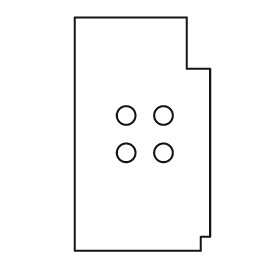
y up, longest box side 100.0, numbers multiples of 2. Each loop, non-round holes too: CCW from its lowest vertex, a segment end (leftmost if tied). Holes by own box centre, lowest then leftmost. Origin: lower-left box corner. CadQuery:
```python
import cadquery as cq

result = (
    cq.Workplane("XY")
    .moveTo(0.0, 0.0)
    .lineTo(54.0, 0.0)
    .lineTo(54.0, 6.0)
    .lineTo(58.0, 6.0)
    .lineTo(58.0, 78.0)
    .lineTo(48.0, 78.0)
    .lineTo(48.0, 100.0)
    .lineTo(0.0, 100.0)
    .close()
    .moveTo(22.0, 42.0)
    .circle(4.0)
    .moveTo(38.0, 42.0)
    .circle(4.0)
    .moveTo(22.0, 58.0)
    .circle(4.0)
    .moveTo(38.0, 58.0)
    .circle(4.0)
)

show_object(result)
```